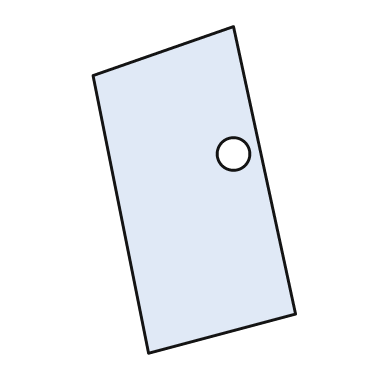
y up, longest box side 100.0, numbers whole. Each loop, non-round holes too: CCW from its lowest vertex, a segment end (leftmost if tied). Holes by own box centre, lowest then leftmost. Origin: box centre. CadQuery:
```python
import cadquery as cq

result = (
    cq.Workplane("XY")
    .moveTo(-14.0, -50.0)
    .lineTo(31.0, -38.0)
    .lineTo(12.0, 50.0)
    .lineTo(-31.0, 35.0)
    .close()
    .moveTo(12.0, 11.0)
    .circle(5.0)
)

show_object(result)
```